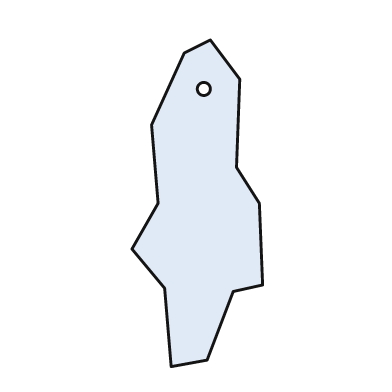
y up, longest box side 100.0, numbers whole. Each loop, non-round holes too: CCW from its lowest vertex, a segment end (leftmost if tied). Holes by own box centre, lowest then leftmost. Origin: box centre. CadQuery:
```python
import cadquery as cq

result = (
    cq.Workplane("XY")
    .moveTo(-8.0, -50.0)
    .lineTo(3.0, -48.0)
    .lineTo(11.0, -27.0)
    .lineTo(20.0, -25.0)
    .lineTo(19.0, 0.0)
    .lineTo(12.0, 11.0)
    .lineTo(13.0, 38.0)
    .lineTo(4.0, 50.0)
    .lineTo(-4.0, 46.0)
    .lineTo(-14.0, 24.0)
    .lineTo(-12.0, 0.0)
    .lineTo(-20.0, -14.0)
    .lineTo(-10.0, -26.0)
    .close()
    .moveTo(2.0, 35.0)
    .circle(2.0)
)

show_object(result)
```